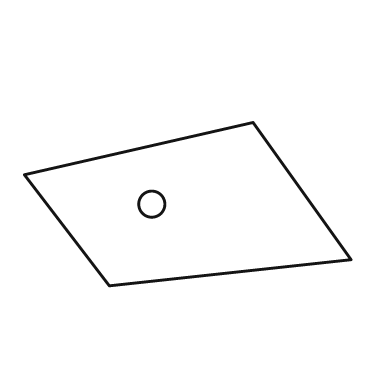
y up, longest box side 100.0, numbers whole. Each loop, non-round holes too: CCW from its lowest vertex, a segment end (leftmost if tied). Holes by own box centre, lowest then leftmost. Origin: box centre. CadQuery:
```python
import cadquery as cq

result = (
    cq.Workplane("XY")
    .moveTo(-24.0, -25.0)
    .lineTo(50.0, -17.0)
    .lineTo(20.0, 25.0)
    .lineTo(-50.0, 9.0)
    .close()
    .moveTo(-11.0, 0.0)
    .circle(4.0)
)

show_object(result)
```